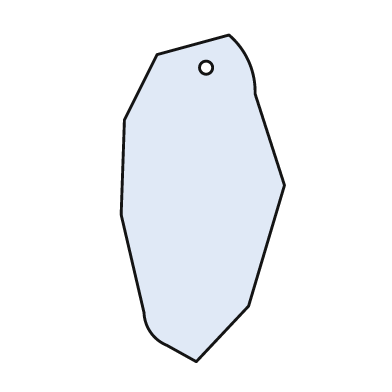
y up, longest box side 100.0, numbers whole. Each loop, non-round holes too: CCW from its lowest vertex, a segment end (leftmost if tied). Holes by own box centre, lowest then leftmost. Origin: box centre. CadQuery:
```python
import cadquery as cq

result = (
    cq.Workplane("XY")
    .moveTo(-2.0, -50.0)
    .lineTo(14.0, -33.0)
    .lineTo(25.0, 4.0)
    .lineTo(16.0, 32.0)
    .threePointArc((14.0, 42.0), (8.0, 50.0))
    .lineTo(-14.0, 44.0)
    .lineTo(-24.0, 24.0)
    .lineTo(-25.0, -5.0)
    .lineTo(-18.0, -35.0)
    .threePointArc((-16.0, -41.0), (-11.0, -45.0))
    .close()
    .moveTo(1.0, 40.0)
    .circle(2.0)
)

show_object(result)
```